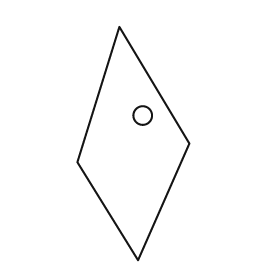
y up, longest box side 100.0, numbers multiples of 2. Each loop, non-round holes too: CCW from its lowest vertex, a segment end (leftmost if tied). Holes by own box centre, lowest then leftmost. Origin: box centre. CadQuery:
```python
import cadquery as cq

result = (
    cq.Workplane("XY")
    .moveTo(2.0, -50.0)
    .lineTo(24.0, 0.0)
    .lineTo(-6.0, 50.0)
    .lineTo(-24.0, -8.0)
    .close()
    .moveTo(4.0, 12.0)
    .circle(4.0)
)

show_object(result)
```